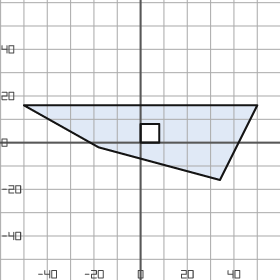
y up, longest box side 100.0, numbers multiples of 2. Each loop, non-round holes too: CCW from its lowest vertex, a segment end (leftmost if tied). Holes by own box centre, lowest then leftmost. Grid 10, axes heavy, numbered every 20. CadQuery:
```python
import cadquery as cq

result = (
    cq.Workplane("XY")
    .moveTo(34.0, -16.0)
    .lineTo(50.0, 16.0)
    .lineTo(-50.0, 16.0)
    .lineTo(-18.0, -2.0)
    .close()
    .moveTo(0.0, 0.0)
    .lineTo(8.0, 0.0)
    .lineTo(8.0, 8.0)
    .lineTo(0.0, 8.0)
    .close()
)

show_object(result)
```